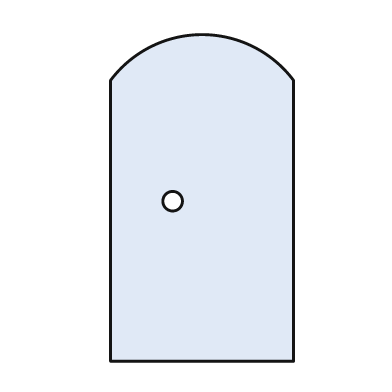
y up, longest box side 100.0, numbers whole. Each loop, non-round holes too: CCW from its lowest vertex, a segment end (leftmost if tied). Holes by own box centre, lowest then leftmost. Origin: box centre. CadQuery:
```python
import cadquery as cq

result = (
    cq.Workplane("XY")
    .moveTo(-28.0, -50.0)
    .lineTo(28.0, -50.0)
    .lineTo(28.0, 36.0)
    .threePointArc((0.0, 50.0), (-28.0, 36.0))
    .close()
    .moveTo(-9.0, -1.0)
    .circle(3.0)
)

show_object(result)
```